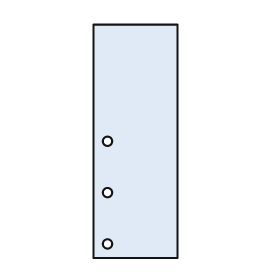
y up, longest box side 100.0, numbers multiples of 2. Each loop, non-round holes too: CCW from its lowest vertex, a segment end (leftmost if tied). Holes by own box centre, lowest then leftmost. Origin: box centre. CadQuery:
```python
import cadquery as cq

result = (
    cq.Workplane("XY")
    .moveTo(-18.0, -50.0)
    .lineTo(18.0, -50.0)
    .lineTo(18.0, 50.0)
    .lineTo(-18.0, 50.0)
    .close()
    .moveTo(-12.0, -44.0)
    .circle(2.0)
    .moveTo(-12.0, -22.0)
    .circle(2.0)
    .moveTo(-12.0, 0.0)
    .circle(2.0)
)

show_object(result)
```